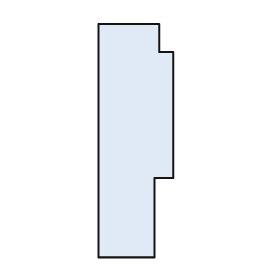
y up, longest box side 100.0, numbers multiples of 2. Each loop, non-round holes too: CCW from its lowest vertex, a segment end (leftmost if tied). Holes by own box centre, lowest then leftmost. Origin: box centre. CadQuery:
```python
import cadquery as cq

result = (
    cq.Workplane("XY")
    .moveTo(-16.0, -50.0)
    .lineTo(8.0, -50.0)
    .lineTo(8.0, -16.0)
    .lineTo(16.0, -16.0)
    .lineTo(16.0, 38.0)
    .lineTo(10.0, 38.0)
    .lineTo(10.0, 50.0)
    .lineTo(-16.0, 50.0)
    .close()
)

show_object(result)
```